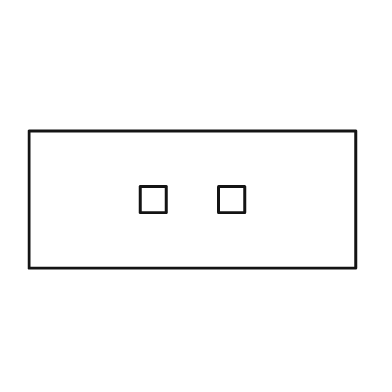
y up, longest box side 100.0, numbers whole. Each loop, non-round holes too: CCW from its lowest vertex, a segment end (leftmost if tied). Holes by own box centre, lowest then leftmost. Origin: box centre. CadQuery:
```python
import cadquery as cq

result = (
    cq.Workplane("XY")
    .moveTo(-50.0, -21.0)
    .lineTo(50.0, -21.0)
    .lineTo(50.0, 21.0)
    .lineTo(-50.0, 21.0)
    .close()
    .moveTo(-16.0, -4.0)
    .lineTo(-8.0, -4.0)
    .lineTo(-8.0, 4.0)
    .lineTo(-16.0, 4.0)
    .close()
    .moveTo(8.0, -4.0)
    .lineTo(16.0, -4.0)
    .lineTo(16.0, 4.0)
    .lineTo(8.0, 4.0)
    .close()
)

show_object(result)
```